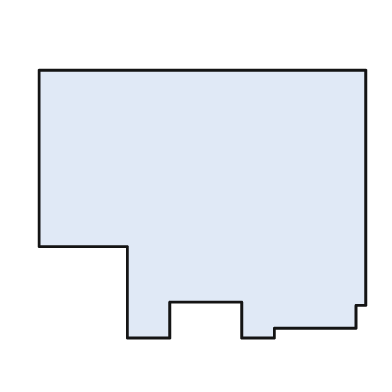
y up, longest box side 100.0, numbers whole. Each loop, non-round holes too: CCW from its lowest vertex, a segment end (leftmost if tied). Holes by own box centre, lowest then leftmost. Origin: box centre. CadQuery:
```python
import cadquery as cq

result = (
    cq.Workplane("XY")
    .moveTo(-23.0, -41.0)
    .lineTo(-10.0, -41.0)
    .lineTo(-10.0, -30.0)
    .lineTo(12.0, -30.0)
    .lineTo(12.0, -41.0)
    .lineTo(22.0, -41.0)
    .lineTo(22.0, -38.0)
    .lineTo(47.0, -38.0)
    .lineTo(47.0, -31.0)
    .lineTo(50.0, -31.0)
    .lineTo(50.0, 41.0)
    .lineTo(-50.0, 41.0)
    .lineTo(-50.0, -13.0)
    .lineTo(-23.0, -13.0)
    .close()
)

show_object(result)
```